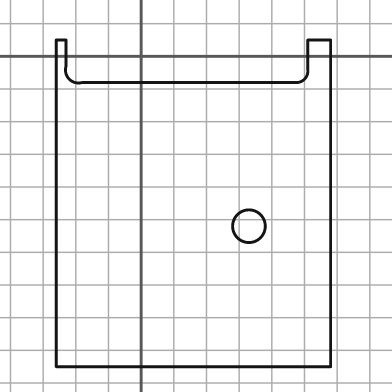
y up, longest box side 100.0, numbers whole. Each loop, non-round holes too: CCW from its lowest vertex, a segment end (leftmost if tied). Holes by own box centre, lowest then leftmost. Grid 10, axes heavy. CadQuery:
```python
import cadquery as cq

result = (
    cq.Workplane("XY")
    .moveTo(-26.0, -95.0)
    .lineTo(58.0, -95.0)
    .lineTo(58.0, 5.0)
    .lineTo(51.0, 5.0)
    .lineTo(51.0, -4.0)
    .threePointArc((50.0, -7.0), (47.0, -8.0))
    .lineTo(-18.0, -8.0)
    .threePointArc((-22.0, -7.0), (-23.0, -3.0))
    .lineTo(-23.0, 5.0)
    .lineTo(-26.0, 5.0)
    .close()
    .moveTo(33.0, -52.0)
    .circle(5.0)
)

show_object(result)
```